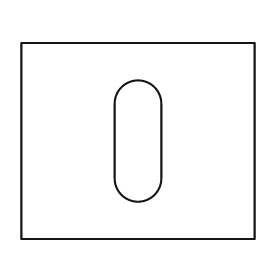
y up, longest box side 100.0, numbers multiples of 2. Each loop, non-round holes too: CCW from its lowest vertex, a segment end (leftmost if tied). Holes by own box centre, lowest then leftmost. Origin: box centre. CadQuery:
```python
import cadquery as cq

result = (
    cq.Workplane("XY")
    .moveTo(-50.0, -42.0)
    .lineTo(50.0, -42.0)
    .lineTo(50.0, 42.0)
    .lineTo(-50.0, 42.0)
    .close()
    .moveTo(-10.0, -16.0)
    .threePointArc((0.0, -26.0), (10.0, -16.0))
    .lineTo(10.0, 16.0)
    .threePointArc((0.0, 26.0), (-10.0, 16.0))
    .close()
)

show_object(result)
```